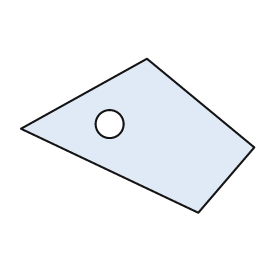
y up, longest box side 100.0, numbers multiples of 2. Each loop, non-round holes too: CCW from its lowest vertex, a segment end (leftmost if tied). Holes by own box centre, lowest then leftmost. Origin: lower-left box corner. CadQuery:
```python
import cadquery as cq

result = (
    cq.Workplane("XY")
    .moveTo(76.0, 0.0)
    .lineTo(100.0, 28.0)
    .lineTo(54.0, 66.0)
    .lineTo(0.0, 36.0)
    .close()
    .moveTo(38.0, 38.0)
    .circle(6.0)
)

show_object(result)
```